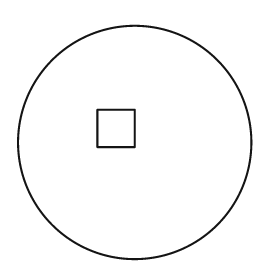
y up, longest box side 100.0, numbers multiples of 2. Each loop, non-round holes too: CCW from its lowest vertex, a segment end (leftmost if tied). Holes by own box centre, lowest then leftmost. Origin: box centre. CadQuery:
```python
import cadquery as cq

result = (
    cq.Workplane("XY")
    .moveTo(0.0, 0.0)
    .circle(50.0)
    .moveTo(-16.0, -2.0)
    .lineTo(0.0, -2.0)
    .lineTo(0.0, 14.0)
    .lineTo(-16.0, 14.0)
    .close()
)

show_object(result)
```